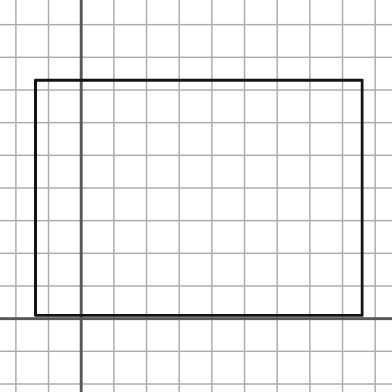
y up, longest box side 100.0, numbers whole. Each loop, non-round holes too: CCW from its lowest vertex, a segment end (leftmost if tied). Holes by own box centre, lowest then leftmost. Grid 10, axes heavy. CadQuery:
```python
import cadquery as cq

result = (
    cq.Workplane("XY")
    .moveTo(-14.0, 1.0)
    .lineTo(86.0, 1.0)
    .lineTo(86.0, 73.0)
    .lineTo(-14.0, 73.0)
    .close()
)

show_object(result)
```